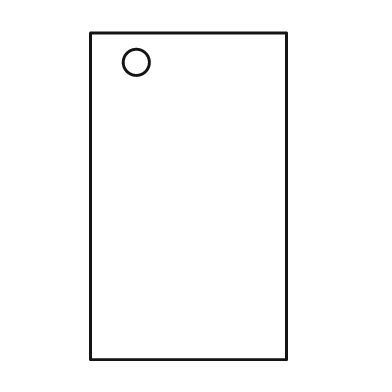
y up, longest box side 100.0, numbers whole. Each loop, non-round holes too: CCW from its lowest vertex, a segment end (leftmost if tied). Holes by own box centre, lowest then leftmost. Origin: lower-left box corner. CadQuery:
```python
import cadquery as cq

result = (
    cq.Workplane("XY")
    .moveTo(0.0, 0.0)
    .lineTo(60.0, 0.0)
    .lineTo(60.0, 100.0)
    .lineTo(0.0, 100.0)
    .close()
    .moveTo(14.0, 91.0)
    .circle(4.0)
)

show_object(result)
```